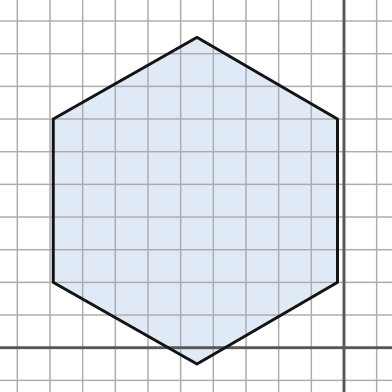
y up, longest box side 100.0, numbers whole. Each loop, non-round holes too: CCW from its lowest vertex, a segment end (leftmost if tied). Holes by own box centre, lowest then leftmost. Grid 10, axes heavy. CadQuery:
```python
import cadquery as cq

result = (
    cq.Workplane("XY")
    .moveTo(-45.0, -5.0)
    .lineTo(-2.0, 20.0)
    .lineTo(-2.0, 70.0)
    .lineTo(-45.0, 95.0)
    .lineTo(-89.0, 70.0)
    .lineTo(-89.0, 20.0)
    .close()
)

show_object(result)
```